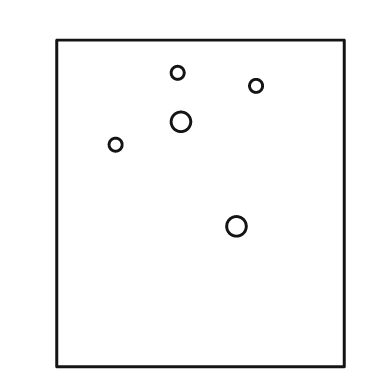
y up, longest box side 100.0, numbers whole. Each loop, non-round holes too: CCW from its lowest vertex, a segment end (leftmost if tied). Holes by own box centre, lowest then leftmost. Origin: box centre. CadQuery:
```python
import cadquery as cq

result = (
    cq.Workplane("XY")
    .moveTo(-44.0, -50.0)
    .lineTo(44.0, -50.0)
    .lineTo(44.0, 50.0)
    .lineTo(-44.0, 50.0)
    .close()
    .moveTo(11.0, -7.0)
    .circle(3.0)
    .moveTo(-26.0, 18.0)
    .circle(2.0)
    .moveTo(-6.0, 25.0)
    .circle(3.0)
    .moveTo(17.0, 36.0)
    .circle(2.0)
    .moveTo(-7.0, 40.0)
    .circle(2.0)
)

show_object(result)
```